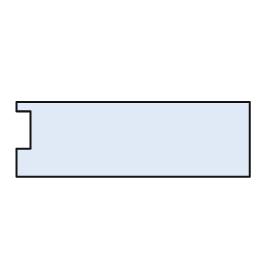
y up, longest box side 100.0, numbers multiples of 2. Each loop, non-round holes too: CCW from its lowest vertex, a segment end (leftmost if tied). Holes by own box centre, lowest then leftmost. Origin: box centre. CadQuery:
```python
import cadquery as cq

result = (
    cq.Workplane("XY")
    .moveTo(-50.0, -16.0)
    .lineTo(50.0, -16.0)
    .lineTo(50.0, 16.0)
    .lineTo(-50.0, 16.0)
    .lineTo(-50.0, 12.0)
    .lineTo(-44.0, 12.0)
    .lineTo(-44.0, -4.0)
    .lineTo(-50.0, -4.0)
    .close()
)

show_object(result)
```